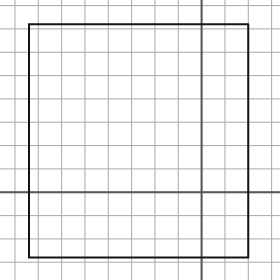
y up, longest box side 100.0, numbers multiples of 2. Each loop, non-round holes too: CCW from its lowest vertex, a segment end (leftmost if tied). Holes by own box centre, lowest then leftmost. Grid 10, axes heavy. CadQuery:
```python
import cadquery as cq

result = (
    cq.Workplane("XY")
    .moveTo(-74.0, -28.0)
    .lineTo(20.0, -28.0)
    .lineTo(20.0, 72.0)
    .lineTo(-74.0, 72.0)
    .close()
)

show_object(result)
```